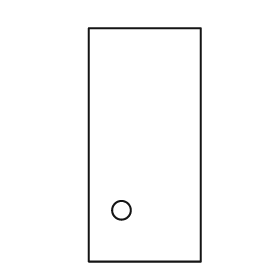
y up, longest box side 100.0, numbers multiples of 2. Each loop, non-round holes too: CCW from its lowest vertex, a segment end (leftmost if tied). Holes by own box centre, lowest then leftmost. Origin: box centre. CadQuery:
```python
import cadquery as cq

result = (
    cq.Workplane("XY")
    .moveTo(-24.0, -50.0)
    .lineTo(24.0, -50.0)
    .lineTo(24.0, 50.0)
    .lineTo(-24.0, 50.0)
    .close()
    .moveTo(-10.0, -28.0)
    .circle(4.0)
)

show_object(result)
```